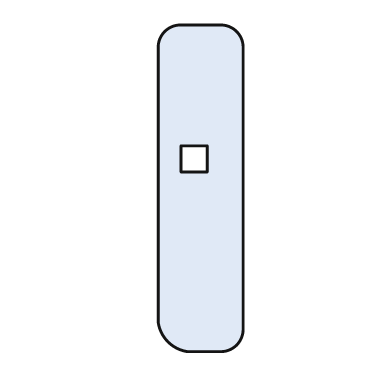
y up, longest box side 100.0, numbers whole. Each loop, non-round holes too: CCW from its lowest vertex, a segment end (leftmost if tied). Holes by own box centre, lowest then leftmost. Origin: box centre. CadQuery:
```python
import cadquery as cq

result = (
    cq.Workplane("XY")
    .moveTo(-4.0, -50.0)
    .lineTo(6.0, -50.0)
    .threePointArc((11.0, -48.0), (13.0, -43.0))
    .lineTo(13.0, 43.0)
    .threePointArc((11.0, 48.0), (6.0, 50.0))
    .lineTo(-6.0, 50.0)
    .threePointArc((-11.0, 48.0), (-13.0, 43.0))
    .lineTo(-13.0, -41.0)
    .threePointArc((-10.0, -47.0), (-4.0, -50.0))
    .close()
    .moveTo(-6.0, 5.0)
    .lineTo(2.0, 5.0)
    .lineTo(2.0, 13.0)
    .lineTo(-6.0, 13.0)
    .close()
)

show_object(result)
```